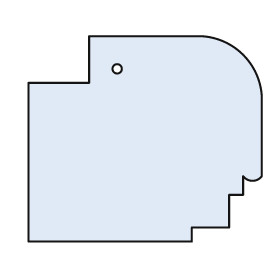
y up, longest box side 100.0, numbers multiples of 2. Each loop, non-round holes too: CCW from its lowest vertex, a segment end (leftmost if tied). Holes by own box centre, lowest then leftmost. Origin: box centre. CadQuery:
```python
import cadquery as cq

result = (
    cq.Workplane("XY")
    .moveTo(-50.0, -44.0)
    .lineTo(20.0, -44.0)
    .lineTo(20.0, -38.0)
    .lineTo(36.0, -38.0)
    .lineTo(36.0, -24.0)
    .lineTo(42.0, -24.0)
    .lineTo(42.0, -16.0)
    .threePointArc((46.0, -18.0), (50.0, -16.0))
    .lineTo(50.0, 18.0)
    .threePointArc((42.0, 36.0), (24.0, 44.0))
    .lineTo(-24.0, 44.0)
    .lineTo(-24.0, 24.0)
    .lineTo(-50.0, 24.0)
    .close()
    .moveTo(-12.0, 30.0)
    .circle(2.0)
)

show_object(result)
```